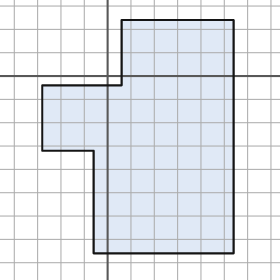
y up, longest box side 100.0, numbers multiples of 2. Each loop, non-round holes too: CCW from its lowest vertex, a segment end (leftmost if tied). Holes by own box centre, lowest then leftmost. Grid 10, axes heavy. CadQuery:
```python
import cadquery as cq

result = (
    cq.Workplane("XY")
    .moveTo(-6.0, -76.0)
    .lineTo(54.0, -76.0)
    .lineTo(54.0, 24.0)
    .lineTo(6.0, 24.0)
    .lineTo(6.0, -4.0)
    .lineTo(-28.0, -4.0)
    .lineTo(-28.0, -32.0)
    .lineTo(-6.0, -32.0)
    .close()
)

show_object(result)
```